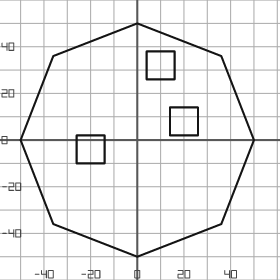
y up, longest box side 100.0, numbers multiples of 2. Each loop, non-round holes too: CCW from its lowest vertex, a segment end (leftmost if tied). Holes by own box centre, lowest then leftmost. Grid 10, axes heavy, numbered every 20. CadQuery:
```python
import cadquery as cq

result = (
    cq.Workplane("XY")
    .moveTo(0.0, -50.0)
    .lineTo(36.0, -36.0)
    .lineTo(50.0, 0.0)
    .lineTo(36.0, 36.0)
    .lineTo(0.0, 50.0)
    .lineTo(-36.0, 36.0)
    .lineTo(-50.0, 0.0)
    .lineTo(-36.0, -36.0)
    .close()
    .moveTo(-26.0, -10.0)
    .lineTo(-14.0, -10.0)
    .lineTo(-14.0, 2.0)
    .lineTo(-26.0, 2.0)
    .close()
    .moveTo(14.0, 2.0)
    .lineTo(26.0, 2.0)
    .lineTo(26.0, 14.0)
    .lineTo(14.0, 14.0)
    .close()
    .moveTo(4.0, 26.0)
    .lineTo(16.0, 26.0)
    .lineTo(16.0, 38.0)
    .lineTo(4.0, 38.0)
    .close()
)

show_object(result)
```